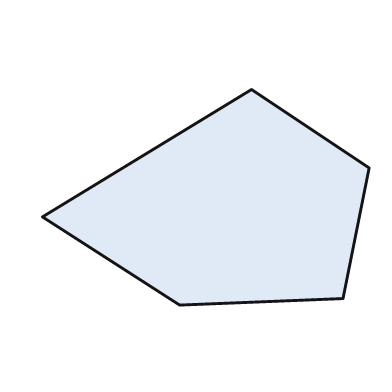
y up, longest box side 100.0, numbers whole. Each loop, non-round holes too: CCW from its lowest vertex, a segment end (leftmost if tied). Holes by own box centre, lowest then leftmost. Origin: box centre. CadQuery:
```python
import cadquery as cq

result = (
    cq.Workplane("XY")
    .moveTo(-8.0, -33.0)
    .lineTo(42.0, -31.0)
    .lineTo(50.0, 9.0)
    .lineTo(14.0, 33.0)
    .lineTo(-50.0, -6.0)
    .close()
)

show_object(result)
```